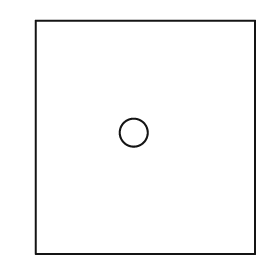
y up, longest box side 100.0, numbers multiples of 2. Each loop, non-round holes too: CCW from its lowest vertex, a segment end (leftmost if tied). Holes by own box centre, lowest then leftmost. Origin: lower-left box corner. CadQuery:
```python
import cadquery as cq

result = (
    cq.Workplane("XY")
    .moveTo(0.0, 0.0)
    .lineTo(94.0, 0.0)
    .lineTo(94.0, 100.0)
    .lineTo(0.0, 100.0)
    .close()
    .moveTo(42.0, 52.0)
    .circle(6.0)
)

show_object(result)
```